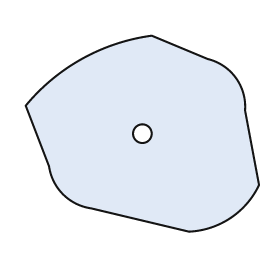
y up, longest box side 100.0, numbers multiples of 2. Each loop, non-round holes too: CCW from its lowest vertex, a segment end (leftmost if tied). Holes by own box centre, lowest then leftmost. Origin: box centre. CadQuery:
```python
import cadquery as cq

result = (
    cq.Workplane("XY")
    .moveTo(20.0, -42.0)
    .threePointArc((38.0, -36.0), (50.0, -22.0))
    .lineTo(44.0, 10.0)
    .threePointArc((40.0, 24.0), (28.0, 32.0))
    .lineTo(4.0, 42.0)
    .threePointArc((-26.0, 32.0), (-50.0, 12.0))
    .lineTo(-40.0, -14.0)
    .threePointArc((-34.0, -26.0), (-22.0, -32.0))
    .close()
    .moveTo(0.0, 0.0)
    .circle(4.0)
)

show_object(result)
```